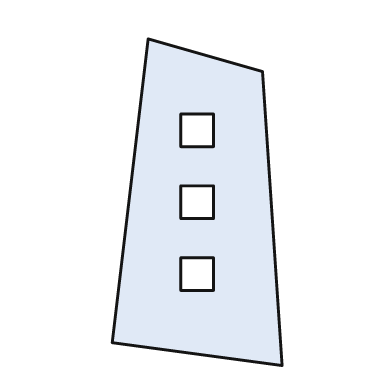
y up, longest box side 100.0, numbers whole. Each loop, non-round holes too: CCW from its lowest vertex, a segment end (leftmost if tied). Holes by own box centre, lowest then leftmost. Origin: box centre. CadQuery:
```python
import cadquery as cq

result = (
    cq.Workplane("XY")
    .moveTo(26.0, -50.0)
    .lineTo(20.0, 40.0)
    .lineTo(-15.0, 50.0)
    .lineTo(-26.0, -43.0)
    .close()
    .moveTo(-5.0, -27.0)
    .lineTo(5.0, -27.0)
    .lineTo(5.0, -17.0)
    .lineTo(-5.0, -17.0)
    .close()
    .moveTo(-5.0, -5.0)
    .lineTo(5.0, -5.0)
    .lineTo(5.0, 5.0)
    .lineTo(-5.0, 5.0)
    .close()
    .moveTo(-5.0, 17.0)
    .lineTo(5.0, 17.0)
    .lineTo(5.0, 27.0)
    .lineTo(-5.0, 27.0)
    .close()
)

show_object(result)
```